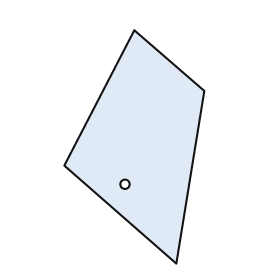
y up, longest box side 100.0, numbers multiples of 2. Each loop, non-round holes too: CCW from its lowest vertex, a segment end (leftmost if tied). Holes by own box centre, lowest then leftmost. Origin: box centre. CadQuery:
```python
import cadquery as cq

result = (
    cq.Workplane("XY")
    .moveTo(18.0, -50.0)
    .lineTo(30.0, 24.0)
    .lineTo(0.0, 50.0)
    .lineTo(-30.0, -8.0)
    .close()
    .moveTo(-4.0, -16.0)
    .circle(2.0)
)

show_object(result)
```